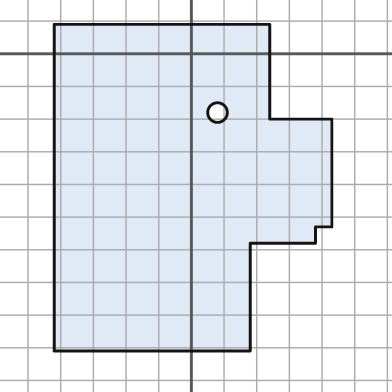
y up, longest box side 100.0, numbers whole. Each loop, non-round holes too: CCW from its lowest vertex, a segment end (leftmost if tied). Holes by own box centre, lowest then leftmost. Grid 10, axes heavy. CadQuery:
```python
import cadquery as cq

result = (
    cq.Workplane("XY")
    .moveTo(-42.0, -91.0)
    .lineTo(18.0, -91.0)
    .lineTo(18.0, -58.0)
    .lineTo(38.0, -58.0)
    .lineTo(38.0, -53.0)
    .lineTo(43.0, -53.0)
    .lineTo(43.0, -20.0)
    .lineTo(24.0, -20.0)
    .lineTo(24.0, 9.0)
    .lineTo(-42.0, 9.0)
    .close()
    .moveTo(8.0, -18.0)
    .circle(3.0)
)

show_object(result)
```